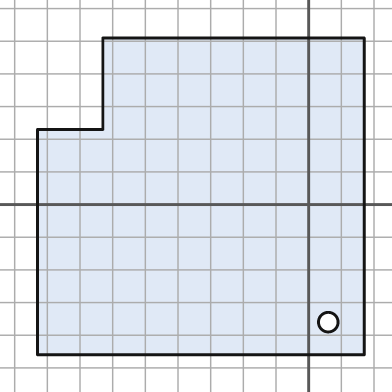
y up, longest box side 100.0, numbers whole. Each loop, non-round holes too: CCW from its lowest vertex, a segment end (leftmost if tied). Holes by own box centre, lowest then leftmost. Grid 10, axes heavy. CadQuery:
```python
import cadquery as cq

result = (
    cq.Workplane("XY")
    .moveTo(-83.0, -46.0)
    .lineTo(17.0, -46.0)
    .lineTo(17.0, 51.0)
    .lineTo(-63.0, 51.0)
    .lineTo(-63.0, 23.0)
    .lineTo(-83.0, 23.0)
    .close()
    .moveTo(6.0, -36.0)
    .circle(3.0)
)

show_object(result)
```